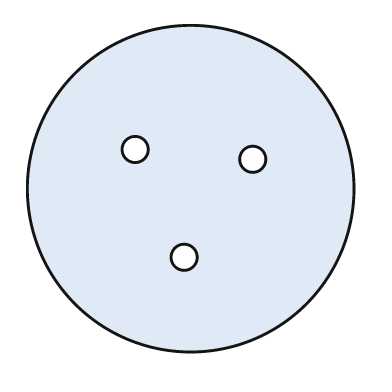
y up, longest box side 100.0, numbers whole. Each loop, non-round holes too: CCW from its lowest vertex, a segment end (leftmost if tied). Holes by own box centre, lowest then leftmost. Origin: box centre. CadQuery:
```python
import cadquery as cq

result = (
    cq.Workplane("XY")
    .moveTo(0.0, 0.0)
    .circle(50.0)
    .moveTo(-2.0, -21.0)
    .circle(4.0)
    .moveTo(19.0, 9.0)
    .circle(4.0)
    .moveTo(-17.0, 12.0)
    .circle(4.0)
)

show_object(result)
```